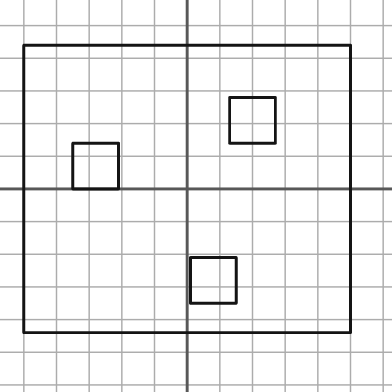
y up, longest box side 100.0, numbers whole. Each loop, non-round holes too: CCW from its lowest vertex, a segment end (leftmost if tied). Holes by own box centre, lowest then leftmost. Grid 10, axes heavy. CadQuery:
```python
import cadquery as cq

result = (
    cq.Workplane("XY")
    .moveTo(-50.0, -44.0)
    .lineTo(50.0, -44.0)
    .lineTo(50.0, 44.0)
    .lineTo(-50.0, 44.0)
    .close()
    .moveTo(1.0, -35.0)
    .lineTo(15.0, -35.0)
    .lineTo(15.0, -21.0)
    .lineTo(1.0, -21.0)
    .close()
    .moveTo(-35.0, 0.0)
    .lineTo(-21.0, 0.0)
    .lineTo(-21.0, 14.0)
    .lineTo(-35.0, 14.0)
    .close()
    .moveTo(13.0, 14.0)
    .lineTo(27.0, 14.0)
    .lineTo(27.0, 28.0)
    .lineTo(13.0, 28.0)
    .close()
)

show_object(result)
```